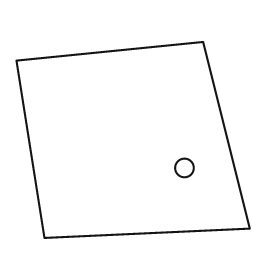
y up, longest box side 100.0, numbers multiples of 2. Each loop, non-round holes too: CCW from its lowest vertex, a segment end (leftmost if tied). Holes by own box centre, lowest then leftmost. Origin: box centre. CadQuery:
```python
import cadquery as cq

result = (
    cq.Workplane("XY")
    .moveTo(-38.0, -42.0)
    .lineTo(50.0, -38.0)
    .lineTo(30.0, 42.0)
    .lineTo(-50.0, 34.0)
    .close()
    .moveTo(22.0, -12.0)
    .circle(4.0)
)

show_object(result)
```